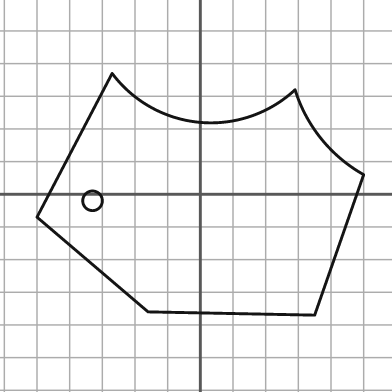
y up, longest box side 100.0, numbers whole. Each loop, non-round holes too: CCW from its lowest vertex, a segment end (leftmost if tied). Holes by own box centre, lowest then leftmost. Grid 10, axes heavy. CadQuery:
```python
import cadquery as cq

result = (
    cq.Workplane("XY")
    .moveTo(35.0, -37.0)
    .lineTo(50.0, 6.0)
    .threePointArc((37.0, 17.0), (29.0, 32.0))
    .threePointArc((0.0, 22.0), (-27.0, 37.0))
    .lineTo(-50.0, -7.0)
    .lineTo(-16.0, -36.0)
    .close()
    .moveTo(-33.0, -2.0)
    .circle(3.0)
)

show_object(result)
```